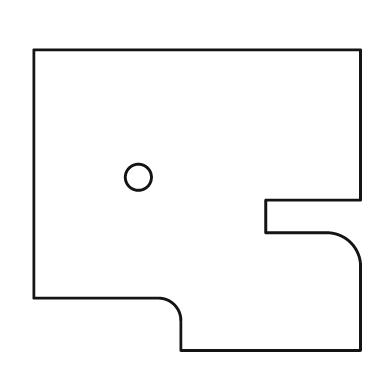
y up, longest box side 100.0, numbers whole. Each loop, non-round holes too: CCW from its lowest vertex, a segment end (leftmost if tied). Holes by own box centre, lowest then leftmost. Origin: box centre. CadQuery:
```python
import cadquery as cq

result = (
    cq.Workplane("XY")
    .moveTo(-5.0, -46.0)
    .lineTo(50.0, -46.0)
    .lineTo(50.0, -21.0)
    .threePointArc((47.0, -13.0), (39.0, -10.0))
    .lineTo(21.0, -10.0)
    .lineTo(21.0, 0.0)
    .lineTo(50.0, 0.0)
    .lineTo(50.0, 46.0)
    .lineTo(-50.0, 46.0)
    .lineTo(-50.0, -30.0)
    .lineTo(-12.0, -30.0)
    .threePointArc((-7.0, -32.0), (-5.0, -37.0))
    .close()
    .moveTo(-18.0, 7.0)
    .circle(4.0)
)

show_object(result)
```